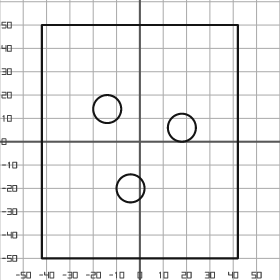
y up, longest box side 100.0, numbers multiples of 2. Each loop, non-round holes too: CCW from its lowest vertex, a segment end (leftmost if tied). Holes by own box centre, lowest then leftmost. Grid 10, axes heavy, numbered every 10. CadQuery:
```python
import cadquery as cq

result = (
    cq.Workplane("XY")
    .moveTo(-42.0, -50.0)
    .lineTo(42.0, -50.0)
    .lineTo(42.0, 50.0)
    .lineTo(-42.0, 50.0)
    .close()
    .moveTo(-4.0, -20.0)
    .circle(6.0)
    .moveTo(18.0, 6.0)
    .circle(6.0)
    .moveTo(-14.0, 14.0)
    .circle(6.0)
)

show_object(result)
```